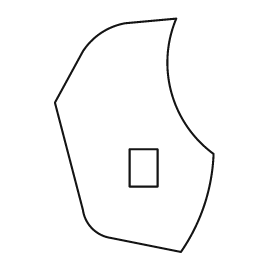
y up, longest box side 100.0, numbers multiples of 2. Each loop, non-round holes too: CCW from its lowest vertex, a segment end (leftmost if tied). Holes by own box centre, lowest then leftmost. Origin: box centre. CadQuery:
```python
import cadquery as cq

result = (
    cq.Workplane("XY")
    .moveTo(20.0, -50.0)
    .threePointArc((30.0, -30.0), (34.0, -8.0))
    .threePointArc((16.0, 18.0), (18.0, 50.0))
    .lineTo(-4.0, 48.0)
    .threePointArc((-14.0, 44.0), (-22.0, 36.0))
    .lineTo(-34.0, 14.0)
    .lineTo(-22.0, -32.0)
    .threePointArc((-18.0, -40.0), (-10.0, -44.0))
    .close()
    .moveTo(-2.0, -22.0)
    .lineTo(10.0, -22.0)
    .lineTo(10.0, -6.0)
    .lineTo(-2.0, -6.0)
    .close()
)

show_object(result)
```